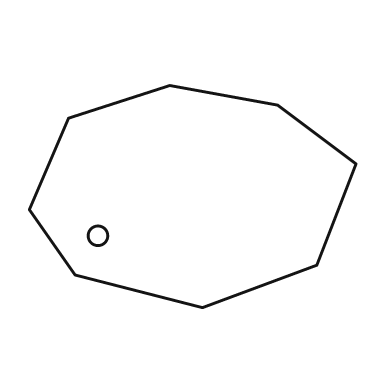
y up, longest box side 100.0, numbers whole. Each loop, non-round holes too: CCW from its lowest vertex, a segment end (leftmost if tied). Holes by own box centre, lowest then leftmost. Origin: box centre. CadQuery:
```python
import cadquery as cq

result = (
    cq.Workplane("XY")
    .moveTo(3.0, -34.0)
    .lineTo(38.0, -21.0)
    .lineTo(50.0, 10.0)
    .lineTo(26.0, 28.0)
    .lineTo(-7.0, 34.0)
    .lineTo(-38.0, 24.0)
    .lineTo(-50.0, -4.0)
    .lineTo(-36.0, -24.0)
    .close()
    .moveTo(-29.0, -12.0)
    .circle(3.0)
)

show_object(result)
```